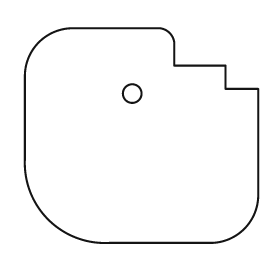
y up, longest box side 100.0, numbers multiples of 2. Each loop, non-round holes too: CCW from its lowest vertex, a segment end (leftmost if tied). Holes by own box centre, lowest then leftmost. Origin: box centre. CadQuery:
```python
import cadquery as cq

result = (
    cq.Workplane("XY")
    .moveTo(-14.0, -46.0)
    .lineTo(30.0, -46.0)
    .threePointArc((44.0, -40.0), (50.0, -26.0))
    .lineTo(50.0, 20.0)
    .lineTo(36.0, 20.0)
    .lineTo(36.0, 30.0)
    .lineTo(14.0, 30.0)
    .lineTo(14.0, 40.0)
    .threePointArc((12.0, 44.0), (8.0, 46.0))
    .lineTo(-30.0, 46.0)
    .threePointArc((-44.0, 40.0), (-50.0, 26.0))
    .lineTo(-50.0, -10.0)
    .threePointArc((-40.0, -36.0), (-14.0, -46.0))
    .close()
    .moveTo(-4.0, 18.0)
    .circle(4.0)
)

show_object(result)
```